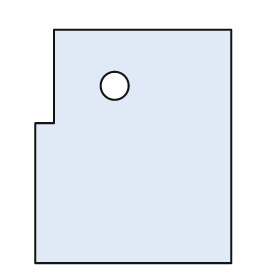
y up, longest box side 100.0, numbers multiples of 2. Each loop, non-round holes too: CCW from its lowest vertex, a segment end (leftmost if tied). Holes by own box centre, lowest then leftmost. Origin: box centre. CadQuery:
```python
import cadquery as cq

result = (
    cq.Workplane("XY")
    .moveTo(-42.0, -50.0)
    .lineTo(42.0, -50.0)
    .lineTo(42.0, 50.0)
    .lineTo(-34.0, 50.0)
    .lineTo(-34.0, 10.0)
    .lineTo(-42.0, 10.0)
    .close()
    .moveTo(-8.0, 26.0)
    .circle(6.0)
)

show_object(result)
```